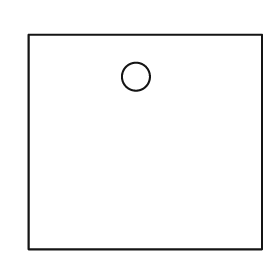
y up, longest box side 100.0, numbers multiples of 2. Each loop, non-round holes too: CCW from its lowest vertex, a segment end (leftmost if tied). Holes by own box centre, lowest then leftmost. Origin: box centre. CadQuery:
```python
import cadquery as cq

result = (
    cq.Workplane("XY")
    .moveTo(-50.0, -46.0)
    .lineTo(50.0, -46.0)
    .lineTo(50.0, 46.0)
    .lineTo(-50.0, 46.0)
    .close()
    .moveTo(-4.0, 28.0)
    .circle(6.0)
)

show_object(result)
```